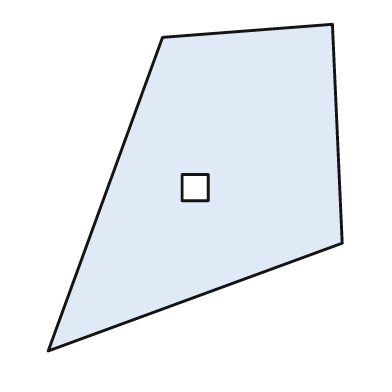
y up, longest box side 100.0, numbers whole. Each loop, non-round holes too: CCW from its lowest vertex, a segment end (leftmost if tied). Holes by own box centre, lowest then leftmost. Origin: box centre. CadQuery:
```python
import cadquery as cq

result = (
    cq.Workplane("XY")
    .moveTo(-45.0, -50.0)
    .lineTo(45.0, -17.0)
    .lineTo(42.0, 50.0)
    .lineTo(-10.0, 46.0)
    .close()
    .moveTo(-4.0, -4.0)
    .lineTo(4.0, -4.0)
    .lineTo(4.0, 4.0)
    .lineTo(-4.0, 4.0)
    .close()
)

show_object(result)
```